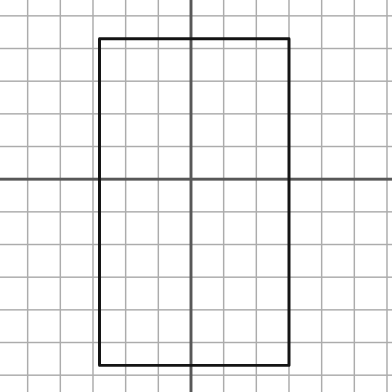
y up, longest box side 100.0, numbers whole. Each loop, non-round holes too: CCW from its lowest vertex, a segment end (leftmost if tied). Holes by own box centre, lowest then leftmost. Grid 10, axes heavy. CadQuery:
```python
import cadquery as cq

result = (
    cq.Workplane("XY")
    .moveTo(-28.0, -57.0)
    .lineTo(30.0, -57.0)
    .lineTo(30.0, 43.0)
    .lineTo(-28.0, 43.0)
    .close()
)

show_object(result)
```